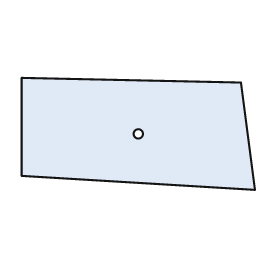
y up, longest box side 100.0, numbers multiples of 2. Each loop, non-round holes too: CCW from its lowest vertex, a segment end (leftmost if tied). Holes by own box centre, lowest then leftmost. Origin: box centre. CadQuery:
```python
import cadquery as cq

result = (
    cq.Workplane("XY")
    .moveTo(50.0, -24.0)
    .lineTo(44.0, 22.0)
    .lineTo(-50.0, 24.0)
    .lineTo(-50.0, -18.0)
    .close()
    .moveTo(0.0, 0.0)
    .circle(2.0)
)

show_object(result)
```